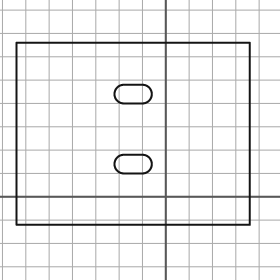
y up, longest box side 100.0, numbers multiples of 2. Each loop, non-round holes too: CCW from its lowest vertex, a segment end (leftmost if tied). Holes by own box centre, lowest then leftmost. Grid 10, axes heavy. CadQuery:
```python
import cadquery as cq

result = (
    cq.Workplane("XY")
    .moveTo(-64.0, -12.0)
    .lineTo(36.0, -12.0)
    .lineTo(36.0, 66.0)
    .lineTo(-64.0, 66.0)
    .close()
    .moveTo(-18.0, 10.0)
    .lineTo(-10.0, 10.0)
    .threePointArc((-6.0, 14.0), (-10.0, 18.0))
    .lineTo(-18.0, 18.0)
    .threePointArc((-22.0, 14.0), (-18.0, 10.0))
    .close()
    .moveTo(-18.0, 40.0)
    .lineTo(-10.0, 40.0)
    .threePointArc((-6.0, 44.0), (-10.0, 48.0))
    .lineTo(-18.0, 48.0)
    .threePointArc((-22.0, 44.0), (-18.0, 40.0))
    .close()
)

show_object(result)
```